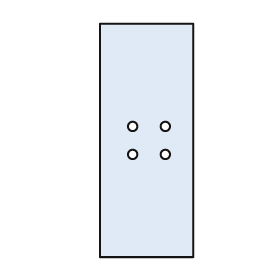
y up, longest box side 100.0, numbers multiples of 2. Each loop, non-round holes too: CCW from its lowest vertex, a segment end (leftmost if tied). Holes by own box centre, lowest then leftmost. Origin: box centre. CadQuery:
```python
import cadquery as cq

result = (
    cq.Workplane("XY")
    .moveTo(-20.0, -50.0)
    .lineTo(20.0, -50.0)
    .lineTo(20.0, 50.0)
    .lineTo(-20.0, 50.0)
    .close()
    .moveTo(-6.0, -6.0)
    .circle(2.0)
    .moveTo(8.0, -6.0)
    .circle(2.0)
    .moveTo(-6.0, 6.0)
    .circle(2.0)
    .moveTo(8.0, 6.0)
    .circle(2.0)
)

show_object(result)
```